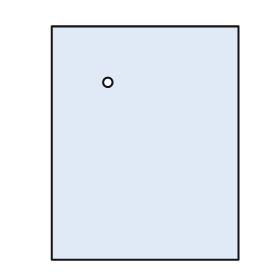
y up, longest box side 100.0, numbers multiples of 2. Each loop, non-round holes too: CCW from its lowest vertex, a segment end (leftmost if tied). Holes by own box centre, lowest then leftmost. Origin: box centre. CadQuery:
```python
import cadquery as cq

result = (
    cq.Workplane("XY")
    .moveTo(-40.0, -50.0)
    .lineTo(40.0, -50.0)
    .lineTo(40.0, 50.0)
    .lineTo(-40.0, 50.0)
    .close()
    .moveTo(-16.0, 26.0)
    .circle(2.0)
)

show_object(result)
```